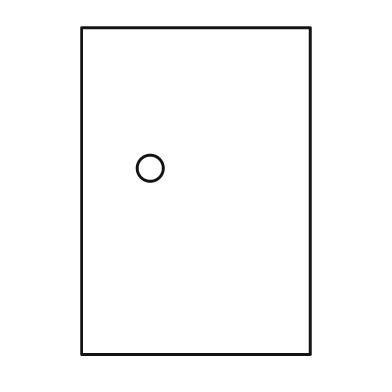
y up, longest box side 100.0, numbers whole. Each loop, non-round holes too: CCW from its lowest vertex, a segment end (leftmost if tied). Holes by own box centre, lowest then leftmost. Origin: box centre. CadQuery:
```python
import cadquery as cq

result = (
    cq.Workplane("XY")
    .moveTo(-35.0, -50.0)
    .lineTo(35.0, -50.0)
    .lineTo(35.0, 50.0)
    .lineTo(-35.0, 50.0)
    .close()
    .moveTo(-14.0, 7.0)
    .circle(4.0)
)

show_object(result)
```